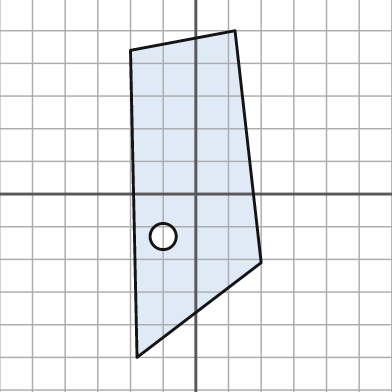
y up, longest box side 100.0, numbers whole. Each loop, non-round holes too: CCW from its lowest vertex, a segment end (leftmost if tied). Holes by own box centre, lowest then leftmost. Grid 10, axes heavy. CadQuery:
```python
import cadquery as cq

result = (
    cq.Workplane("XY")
    .moveTo(-18.0, -50.0)
    .lineTo(20.0, -21.0)
    .lineTo(12.0, 50.0)
    .lineTo(-20.0, 44.0)
    .close()
    .moveTo(-10.0, -13.0)
    .circle(4.0)
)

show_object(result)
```